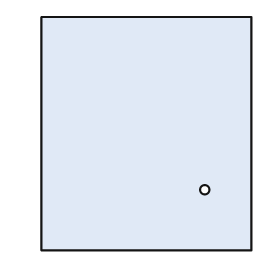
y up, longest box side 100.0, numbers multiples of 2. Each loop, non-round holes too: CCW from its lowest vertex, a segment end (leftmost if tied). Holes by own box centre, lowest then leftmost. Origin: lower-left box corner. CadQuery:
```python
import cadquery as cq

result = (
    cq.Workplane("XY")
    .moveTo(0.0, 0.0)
    .lineTo(90.0, 0.0)
    .lineTo(90.0, 100.0)
    .lineTo(0.0, 100.0)
    .close()
    .moveTo(70.0, 26.0)
    .circle(2.0)
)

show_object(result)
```